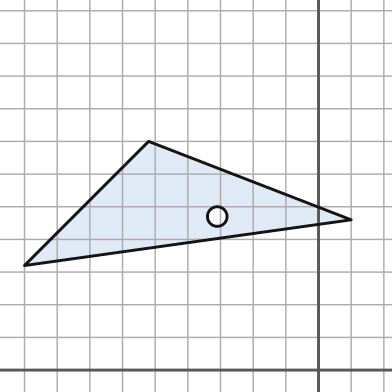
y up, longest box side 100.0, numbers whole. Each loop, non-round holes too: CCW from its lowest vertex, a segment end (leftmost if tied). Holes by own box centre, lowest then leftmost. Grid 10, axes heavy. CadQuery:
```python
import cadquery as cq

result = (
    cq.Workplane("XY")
    .moveTo(-90.0, 32.0)
    .lineTo(10.0, 46.0)
    .lineTo(-52.0, 70.0)
    .close()
    .moveTo(-31.0, 47.0)
    .circle(3.0)
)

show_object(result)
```